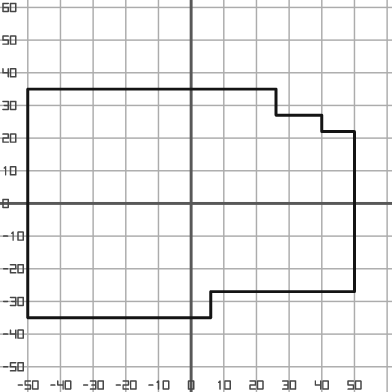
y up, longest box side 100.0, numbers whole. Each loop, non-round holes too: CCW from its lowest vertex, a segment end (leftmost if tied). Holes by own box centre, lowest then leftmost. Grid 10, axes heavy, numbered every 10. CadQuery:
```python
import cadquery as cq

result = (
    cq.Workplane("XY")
    .moveTo(-50.0, -35.0)
    .lineTo(6.0, -35.0)
    .lineTo(6.0, -27.0)
    .lineTo(50.0, -27.0)
    .lineTo(50.0, 22.0)
    .lineTo(40.0, 22.0)
    .lineTo(40.0, 27.0)
    .lineTo(26.0, 27.0)
    .lineTo(26.0, 35.0)
    .lineTo(-50.0, 35.0)
    .close()
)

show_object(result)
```